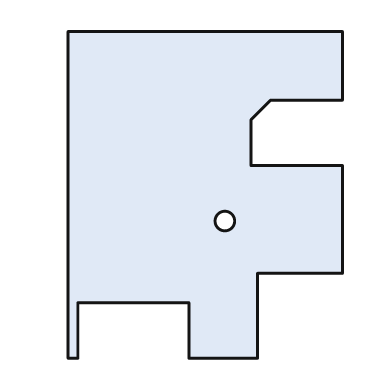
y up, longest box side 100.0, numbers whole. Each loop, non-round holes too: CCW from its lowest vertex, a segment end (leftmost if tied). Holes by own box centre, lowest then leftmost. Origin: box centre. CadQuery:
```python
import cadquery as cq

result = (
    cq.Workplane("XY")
    .moveTo(-42.0, -50.0)
    .lineTo(-39.0, -50.0)
    .lineTo(-39.0, -33.0)
    .lineTo(-5.0, -33.0)
    .lineTo(-5.0, -50.0)
    .lineTo(16.0, -50.0)
    .lineTo(16.0, -24.0)
    .lineTo(42.0, -24.0)
    .lineTo(42.0, 9.0)
    .lineTo(14.0, 9.0)
    .lineTo(14.0, 23.0)
    .lineTo(20.0, 29.0)
    .lineTo(42.0, 29.0)
    .lineTo(42.0, 50.0)
    .lineTo(-42.0, 50.0)
    .close()
    .moveTo(6.0, -8.0)
    .circle(3.0)
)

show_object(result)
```